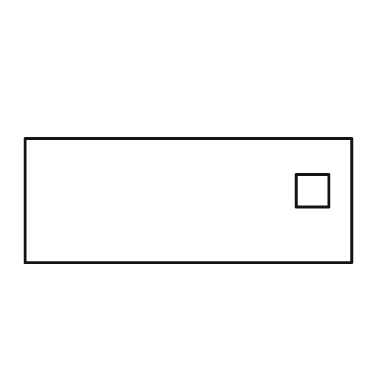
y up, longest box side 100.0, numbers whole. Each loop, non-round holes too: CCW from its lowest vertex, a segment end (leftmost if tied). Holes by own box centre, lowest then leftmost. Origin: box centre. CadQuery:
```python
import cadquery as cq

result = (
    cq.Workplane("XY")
    .moveTo(-50.0, -19.0)
    .lineTo(50.0, -19.0)
    .lineTo(50.0, 19.0)
    .lineTo(-50.0, 19.0)
    .close()
    .moveTo(33.0, -2.0)
    .lineTo(43.0, -2.0)
    .lineTo(43.0, 8.0)
    .lineTo(33.0, 8.0)
    .close()
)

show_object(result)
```